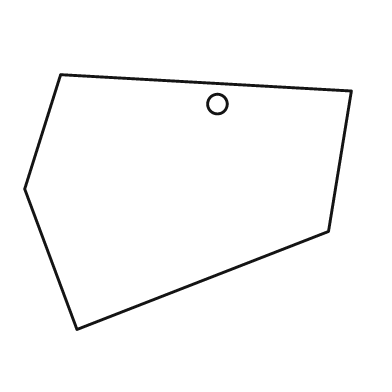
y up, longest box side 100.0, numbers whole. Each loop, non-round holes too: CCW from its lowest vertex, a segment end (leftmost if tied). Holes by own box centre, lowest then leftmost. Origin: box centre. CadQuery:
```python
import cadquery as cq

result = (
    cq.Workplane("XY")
    .moveTo(-34.0, -39.0)
    .lineTo(43.0, -9.0)
    .lineTo(50.0, 34.0)
    .lineTo(-39.0, 39.0)
    .lineTo(-50.0, 4.0)
    .close()
    .moveTo(9.0, 30.0)
    .circle(3.0)
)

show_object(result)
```